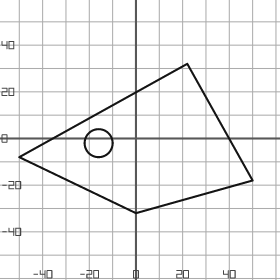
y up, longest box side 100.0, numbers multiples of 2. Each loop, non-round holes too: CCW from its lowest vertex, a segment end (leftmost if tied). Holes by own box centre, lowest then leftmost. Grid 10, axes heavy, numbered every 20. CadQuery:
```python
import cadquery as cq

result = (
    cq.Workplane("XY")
    .moveTo(0.0, -32.0)
    .lineTo(50.0, -18.0)
    .lineTo(22.0, 32.0)
    .lineTo(-50.0, -8.0)
    .close()
    .moveTo(-16.0, -2.0)
    .circle(6.0)
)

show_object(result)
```